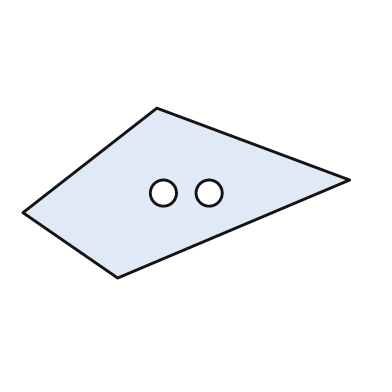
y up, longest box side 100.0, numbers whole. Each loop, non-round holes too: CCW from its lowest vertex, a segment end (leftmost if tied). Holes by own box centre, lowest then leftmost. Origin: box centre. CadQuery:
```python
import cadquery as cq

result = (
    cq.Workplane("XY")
    .moveTo(-21.0, -26.0)
    .lineTo(50.0, 4.0)
    .lineTo(-9.0, 26.0)
    .lineTo(-50.0, -6.0)
    .close()
    .moveTo(-7.0, 0.0)
    .circle(4.0)
    .moveTo(7.0, 0.0)
    .circle(4.0)
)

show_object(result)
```